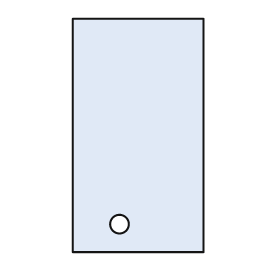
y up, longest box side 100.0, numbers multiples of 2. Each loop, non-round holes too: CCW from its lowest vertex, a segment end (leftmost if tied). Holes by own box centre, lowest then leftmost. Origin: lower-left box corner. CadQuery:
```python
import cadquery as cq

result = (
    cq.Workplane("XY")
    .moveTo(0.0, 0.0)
    .lineTo(56.0, 0.0)
    .lineTo(56.0, 100.0)
    .lineTo(0.0, 100.0)
    .close()
    .moveTo(20.0, 12.0)
    .circle(4.0)
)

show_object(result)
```